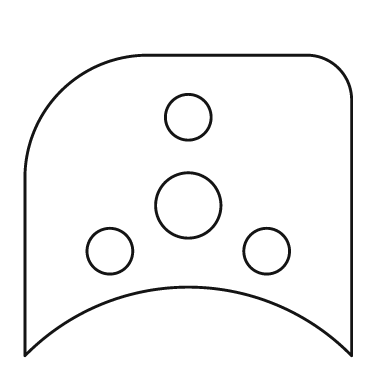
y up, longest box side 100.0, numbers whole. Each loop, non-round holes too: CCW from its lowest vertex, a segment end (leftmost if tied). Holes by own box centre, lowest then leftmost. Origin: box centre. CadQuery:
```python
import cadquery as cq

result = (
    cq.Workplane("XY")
    .moveTo(-50.0, -46.0)
    .threePointArc((0.0, -25.0), (50.0, -46.0))
    .lineTo(50.0, 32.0)
    .threePointArc((46.0, 42.0), (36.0, 46.0))
    .lineTo(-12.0, 46.0)
    .threePointArc((-39.0, 35.0), (-50.0, 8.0))
    .close()
    .moveTo(-24.0, -14.0)
    .circle(7.0)
    .moveTo(24.0, -14.0)
    .circle(7.0)
    .moveTo(0.0, 0.0)
    .circle(10.0)
    .moveTo(0.0, 27.0)
    .circle(7.0)
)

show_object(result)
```